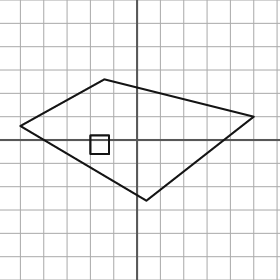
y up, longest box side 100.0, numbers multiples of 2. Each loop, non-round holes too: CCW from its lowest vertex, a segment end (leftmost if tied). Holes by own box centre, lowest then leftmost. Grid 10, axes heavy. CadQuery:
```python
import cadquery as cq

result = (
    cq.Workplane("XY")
    .moveTo(4.0, -26.0)
    .lineTo(50.0, 10.0)
    .lineTo(-14.0, 26.0)
    .lineTo(-50.0, 6.0)
    .close()
    .moveTo(-20.0, -6.0)
    .lineTo(-12.0, -6.0)
    .lineTo(-12.0, 2.0)
    .lineTo(-20.0, 2.0)
    .close()
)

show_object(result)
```